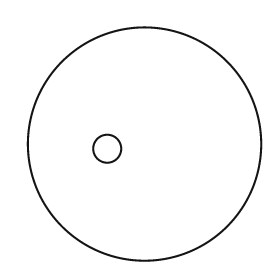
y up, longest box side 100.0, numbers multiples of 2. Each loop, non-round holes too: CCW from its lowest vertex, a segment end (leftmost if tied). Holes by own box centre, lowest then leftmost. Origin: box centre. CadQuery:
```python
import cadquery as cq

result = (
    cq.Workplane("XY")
    .moveTo(0.0, 0.0)
    .circle(50.0)
    .moveTo(-16.0, -2.0)
    .circle(6.0)
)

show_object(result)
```